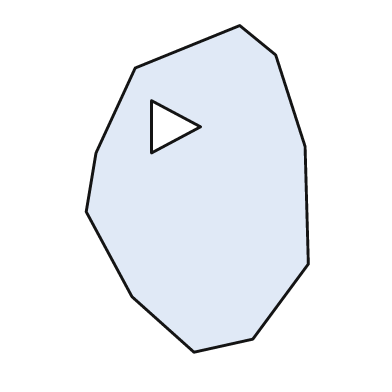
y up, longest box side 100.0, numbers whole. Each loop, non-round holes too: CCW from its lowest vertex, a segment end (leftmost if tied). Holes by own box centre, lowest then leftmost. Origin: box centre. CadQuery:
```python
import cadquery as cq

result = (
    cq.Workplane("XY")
    .moveTo(-1.0, -50.0)
    .lineTo(17.0, -46.0)
    .lineTo(34.0, -23.0)
    .lineTo(33.0, 13.0)
    .lineTo(24.0, 41.0)
    .lineTo(13.0, 50.0)
    .lineTo(-19.0, 37.0)
    .lineTo(-31.0, 11.0)
    .lineTo(-34.0, -7.0)
    .lineTo(-20.0, -33.0)
    .close()
    .moveTo(-14.0, 11.0)
    .lineTo(1.0, 19.0)
    .lineTo(-14.0, 27.0)
    .close()
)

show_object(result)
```